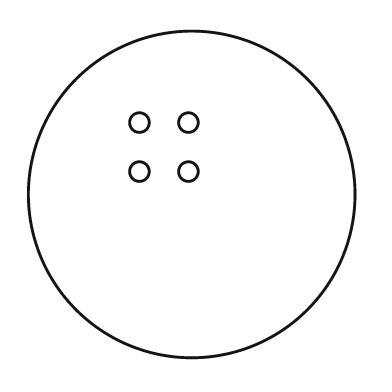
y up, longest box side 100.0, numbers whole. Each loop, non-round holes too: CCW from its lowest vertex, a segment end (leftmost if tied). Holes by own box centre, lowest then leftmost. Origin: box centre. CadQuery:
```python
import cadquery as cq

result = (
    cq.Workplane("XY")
    .moveTo(0.0, 0.0)
    .circle(50.0)
    .moveTo(-16.0, 7.0)
    .circle(3.0)
    .moveTo(-1.0, 7.0)
    .circle(3.0)
    .moveTo(-16.0, 22.0)
    .circle(3.0)
    .moveTo(-1.0, 22.0)
    .circle(3.0)
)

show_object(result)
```